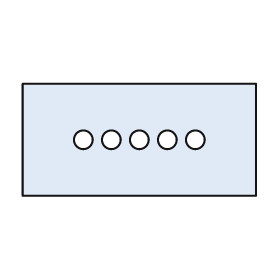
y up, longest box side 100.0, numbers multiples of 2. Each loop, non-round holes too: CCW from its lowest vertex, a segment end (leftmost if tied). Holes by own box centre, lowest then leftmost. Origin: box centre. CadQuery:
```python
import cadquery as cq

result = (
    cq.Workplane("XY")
    .moveTo(-50.0, -24.0)
    .lineTo(50.0, -24.0)
    .lineTo(50.0, 24.0)
    .lineTo(-50.0, 24.0)
    .close()
    .moveTo(-24.0, 0.0)
    .circle(4.0)
    .moveTo(-12.0, 0.0)
    .circle(4.0)
    .moveTo(0.0, 0.0)
    .circle(4.0)
    .moveTo(12.0, 0.0)
    .circle(4.0)
    .moveTo(24.0, 0.0)
    .circle(4.0)
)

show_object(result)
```